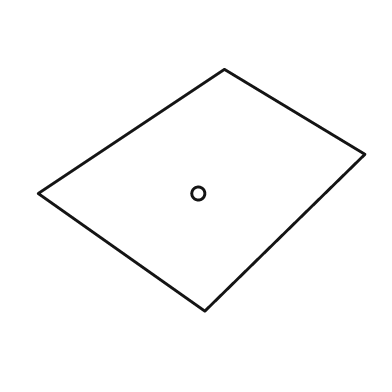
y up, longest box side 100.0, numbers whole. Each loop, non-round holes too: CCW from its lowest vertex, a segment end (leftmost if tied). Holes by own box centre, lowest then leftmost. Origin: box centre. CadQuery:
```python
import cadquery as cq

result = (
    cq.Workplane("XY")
    .moveTo(1.0, -37.0)
    .lineTo(50.0, 11.0)
    .lineTo(7.0, 37.0)
    .lineTo(-50.0, -1.0)
    .close()
    .moveTo(-1.0, -1.0)
    .circle(2.0)
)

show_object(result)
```